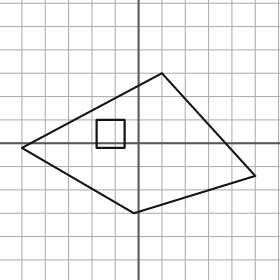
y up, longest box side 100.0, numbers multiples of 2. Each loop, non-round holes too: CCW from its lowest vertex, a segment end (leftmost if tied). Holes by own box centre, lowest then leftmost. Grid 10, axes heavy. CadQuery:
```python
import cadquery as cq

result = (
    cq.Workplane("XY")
    .moveTo(-2.0, -30.0)
    .lineTo(50.0, -14.0)
    .lineTo(10.0, 30.0)
    .lineTo(-50.0, -2.0)
    .close()
    .moveTo(-18.0, -2.0)
    .lineTo(-6.0, -2.0)
    .lineTo(-6.0, 10.0)
    .lineTo(-18.0, 10.0)
    .close()
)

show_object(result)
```